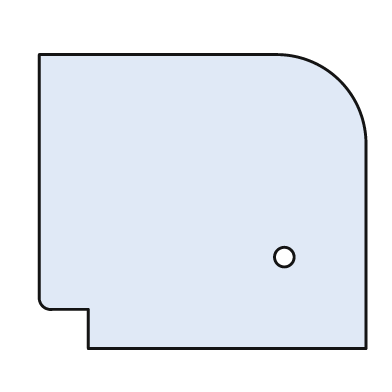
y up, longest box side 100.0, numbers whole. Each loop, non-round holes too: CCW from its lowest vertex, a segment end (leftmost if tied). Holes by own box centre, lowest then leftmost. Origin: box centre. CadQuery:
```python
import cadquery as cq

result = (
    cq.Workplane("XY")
    .moveTo(-35.0, -45.0)
    .lineTo(50.0, -45.0)
    .lineTo(50.0, 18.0)
    .threePointArc((42.0, 37.0), (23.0, 45.0))
    .lineTo(-50.0, 45.0)
    .lineTo(-50.0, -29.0)
    .threePointArc((-49.0, -32.0), (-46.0, -33.0))
    .lineTo(-35.0, -33.0)
    .close()
    .moveTo(25.0, -17.0)
    .circle(3.0)
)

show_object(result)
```